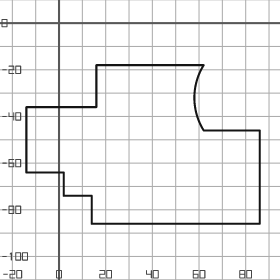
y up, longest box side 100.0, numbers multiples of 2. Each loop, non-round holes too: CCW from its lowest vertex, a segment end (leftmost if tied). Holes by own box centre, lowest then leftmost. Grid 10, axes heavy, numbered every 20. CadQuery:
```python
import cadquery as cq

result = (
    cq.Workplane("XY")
    .moveTo(14.0, -86.0)
    .lineTo(86.0, -86.0)
    .lineTo(86.0, -46.0)
    .lineTo(62.0, -46.0)
    .threePointArc((58.0, -32.0), (62.0, -18.0))
    .lineTo(16.0, -18.0)
    .lineTo(16.0, -36.0)
    .lineTo(-14.0, -36.0)
    .lineTo(-14.0, -64.0)
    .lineTo(2.0, -64.0)
    .lineTo(2.0, -74.0)
    .lineTo(14.0, -74.0)
    .close()
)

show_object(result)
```